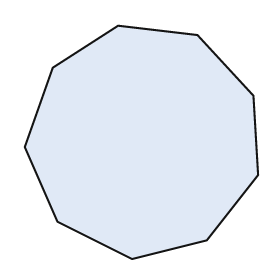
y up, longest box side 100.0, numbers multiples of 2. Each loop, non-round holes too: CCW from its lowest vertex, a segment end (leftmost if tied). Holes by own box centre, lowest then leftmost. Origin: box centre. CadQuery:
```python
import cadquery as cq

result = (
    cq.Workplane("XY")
    .moveTo(-4.0, -50.0)
    .lineTo(28.0, -42.0)
    .lineTo(50.0, -14.0)
    .lineTo(48.0, 20.0)
    .lineTo(24.0, 46.0)
    .lineTo(-10.0, 50.0)
    .lineTo(-38.0, 32.0)
    .lineTo(-50.0, -2.0)
    .lineTo(-36.0, -34.0)
    .close()
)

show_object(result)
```